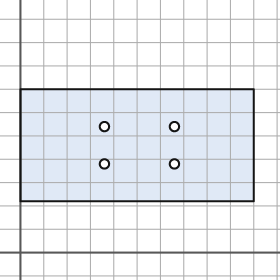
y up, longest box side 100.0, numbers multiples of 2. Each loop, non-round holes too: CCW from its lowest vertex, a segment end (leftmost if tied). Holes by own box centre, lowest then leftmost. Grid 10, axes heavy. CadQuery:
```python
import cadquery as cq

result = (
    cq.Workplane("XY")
    .moveTo(0.0, 22.0)
    .lineTo(100.0, 22.0)
    .lineTo(100.0, 70.0)
    .lineTo(0.0, 70.0)
    .close()
    .moveTo(36.0, 38.0)
    .circle(2.0)
    .moveTo(66.0, 38.0)
    .circle(2.0)
    .moveTo(36.0, 54.0)
    .circle(2.0)
    .moveTo(66.0, 54.0)
    .circle(2.0)
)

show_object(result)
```